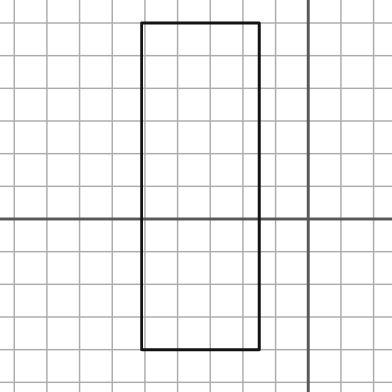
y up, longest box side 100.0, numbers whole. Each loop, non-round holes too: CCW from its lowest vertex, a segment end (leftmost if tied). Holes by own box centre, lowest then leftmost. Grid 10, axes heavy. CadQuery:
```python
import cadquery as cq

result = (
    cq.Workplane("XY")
    .moveTo(-51.0, -40.0)
    .lineTo(-15.0, -40.0)
    .lineTo(-15.0, 60.0)
    .lineTo(-51.0, 60.0)
    .close()
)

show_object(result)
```